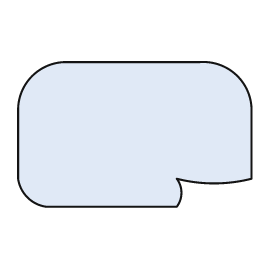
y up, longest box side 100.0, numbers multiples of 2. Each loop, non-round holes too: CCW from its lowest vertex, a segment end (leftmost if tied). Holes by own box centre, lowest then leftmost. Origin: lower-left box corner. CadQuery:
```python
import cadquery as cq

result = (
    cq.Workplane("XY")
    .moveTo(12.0, 0.0)
    .lineTo(68.0, 0.0)
    .threePointArc((70.0, 6.0), (68.0, 12.0))
    .threePointArc((84.0, 10.0), (100.0, 12.0))
    .lineTo(100.0, 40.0)
    .threePointArc((94.0, 56.0), (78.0, 62.0))
    .lineTo(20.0, 62.0)
    .threePointArc((6.0, 56.0), (0.0, 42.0))
    .lineTo(0.0, 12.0)
    .threePointArc((4.0, 4.0), (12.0, 0.0))
    .close()
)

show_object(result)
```